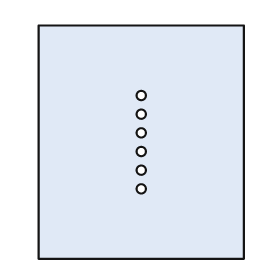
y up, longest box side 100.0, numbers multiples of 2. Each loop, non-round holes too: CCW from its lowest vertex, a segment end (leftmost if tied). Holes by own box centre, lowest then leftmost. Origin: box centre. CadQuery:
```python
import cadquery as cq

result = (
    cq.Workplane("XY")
    .moveTo(-44.0, -50.0)
    .lineTo(44.0, -50.0)
    .lineTo(44.0, 50.0)
    .lineTo(-44.0, 50.0)
    .close()
    .moveTo(0.0, -20.0)
    .circle(2.0)
    .moveTo(0.0, -12.0)
    .circle(2.0)
    .moveTo(0.0, -4.0)
    .circle(2.0)
    .moveTo(0.0, 4.0)
    .circle(2.0)
    .moveTo(0.0, 12.0)
    .circle(2.0)
    .moveTo(0.0, 20.0)
    .circle(2.0)
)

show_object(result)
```